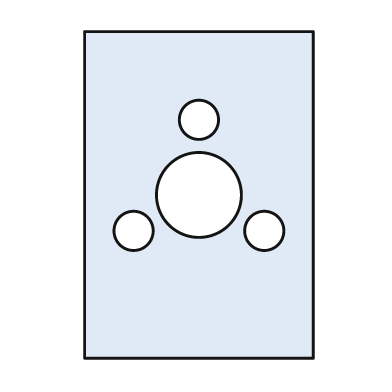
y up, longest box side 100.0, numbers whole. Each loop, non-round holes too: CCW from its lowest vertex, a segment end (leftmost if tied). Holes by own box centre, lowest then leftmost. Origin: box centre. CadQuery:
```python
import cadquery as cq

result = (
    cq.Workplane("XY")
    .moveTo(-35.0, -50.0)
    .lineTo(35.0, -50.0)
    .lineTo(35.0, 50.0)
    .lineTo(-35.0, 50.0)
    .close()
    .moveTo(-20.0, -11.0)
    .circle(6.0)
    .moveTo(20.0, -11.0)
    .circle(6.0)
    .moveTo(0.0, 0.0)
    .circle(13.0)
    .moveTo(0.0, 23.0)
    .circle(6.0)
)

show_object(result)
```